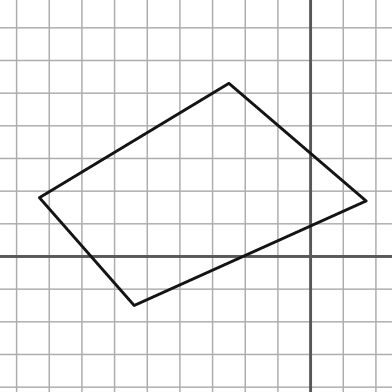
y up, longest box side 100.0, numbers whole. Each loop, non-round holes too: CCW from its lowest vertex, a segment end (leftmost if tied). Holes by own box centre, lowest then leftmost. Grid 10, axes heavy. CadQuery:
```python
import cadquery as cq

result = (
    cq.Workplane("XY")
    .moveTo(-54.0, -15.0)
    .lineTo(17.0, 17.0)
    .lineTo(-25.0, 53.0)
    .lineTo(-83.0, 18.0)
    .close()
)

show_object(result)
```